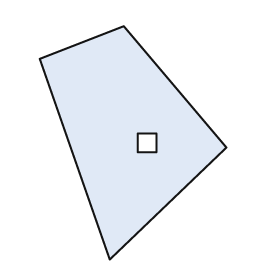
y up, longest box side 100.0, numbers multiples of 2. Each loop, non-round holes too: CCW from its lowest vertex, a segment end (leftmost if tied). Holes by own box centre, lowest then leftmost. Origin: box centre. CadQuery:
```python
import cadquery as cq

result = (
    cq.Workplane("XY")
    .moveTo(-10.0, -50.0)
    .lineTo(40.0, -2.0)
    .lineTo(-4.0, 50.0)
    .lineTo(-40.0, 36.0)
    .close()
    .moveTo(2.0, -4.0)
    .lineTo(10.0, -4.0)
    .lineTo(10.0, 4.0)
    .lineTo(2.0, 4.0)
    .close()
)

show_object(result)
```